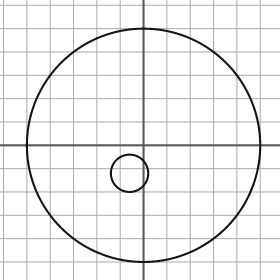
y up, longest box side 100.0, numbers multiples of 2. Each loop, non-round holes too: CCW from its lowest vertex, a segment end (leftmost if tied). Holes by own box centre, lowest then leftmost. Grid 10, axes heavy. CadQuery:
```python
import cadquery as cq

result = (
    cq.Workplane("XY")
    .moveTo(0.0, 0.0)
    .circle(50.0)
    .moveTo(-6.0, -12.0)
    .circle(8.0)
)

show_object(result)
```